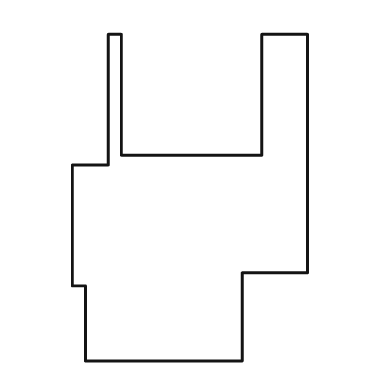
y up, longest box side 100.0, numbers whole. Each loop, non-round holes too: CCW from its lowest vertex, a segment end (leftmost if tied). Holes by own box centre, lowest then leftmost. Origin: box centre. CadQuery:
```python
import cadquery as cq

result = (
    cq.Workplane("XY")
    .moveTo(-32.0, -50.0)
    .lineTo(16.0, -50.0)
    .lineTo(16.0, -23.0)
    .lineTo(36.0, -23.0)
    .lineTo(36.0, 50.0)
    .lineTo(22.0, 50.0)
    .lineTo(22.0, 13.0)
    .lineTo(-21.0, 13.0)
    .lineTo(-21.0, 50.0)
    .lineTo(-25.0, 50.0)
    .lineTo(-25.0, 10.0)
    .lineTo(-36.0, 10.0)
    .lineTo(-36.0, -27.0)
    .lineTo(-32.0, -27.0)
    .close()
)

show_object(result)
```